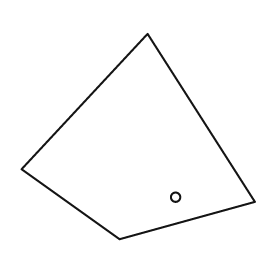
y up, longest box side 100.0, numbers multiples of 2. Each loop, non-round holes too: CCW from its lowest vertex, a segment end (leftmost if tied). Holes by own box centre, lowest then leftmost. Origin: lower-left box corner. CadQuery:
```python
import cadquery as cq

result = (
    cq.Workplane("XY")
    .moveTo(42.0, 0.0)
    .lineTo(100.0, 16.0)
    .lineTo(54.0, 88.0)
    .lineTo(0.0, 30.0)
    .close()
    .moveTo(66.0, 18.0)
    .circle(2.0)
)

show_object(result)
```